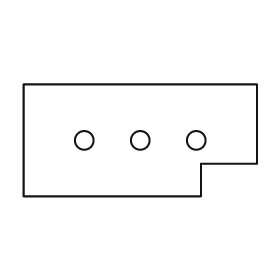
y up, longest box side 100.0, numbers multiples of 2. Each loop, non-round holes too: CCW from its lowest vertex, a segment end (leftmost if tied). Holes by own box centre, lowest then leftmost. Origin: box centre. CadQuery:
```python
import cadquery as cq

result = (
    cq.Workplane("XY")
    .moveTo(-50.0, -24.0)
    .lineTo(26.0, -24.0)
    .lineTo(26.0, -10.0)
    .lineTo(50.0, -10.0)
    .lineTo(50.0, 24.0)
    .lineTo(-50.0, 24.0)
    .close()
    .moveTo(-24.0, 0.0)
    .circle(4.0)
    .moveTo(0.0, 0.0)
    .circle(4.0)
    .moveTo(24.0, 0.0)
    .circle(4.0)
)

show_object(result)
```